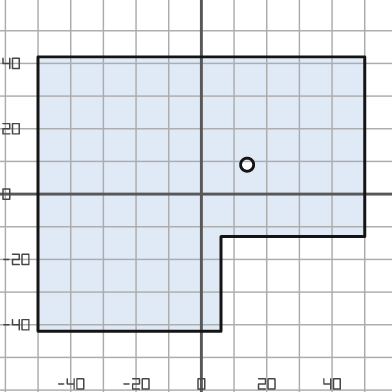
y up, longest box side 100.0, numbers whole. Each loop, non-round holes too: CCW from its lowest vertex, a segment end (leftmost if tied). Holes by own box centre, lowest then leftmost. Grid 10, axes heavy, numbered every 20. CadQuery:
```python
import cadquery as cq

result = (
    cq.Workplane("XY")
    .moveTo(-50.0, -42.0)
    .lineTo(6.0, -42.0)
    .lineTo(6.0, -13.0)
    .lineTo(50.0, -13.0)
    .lineTo(50.0, 42.0)
    .lineTo(-50.0, 42.0)
    .close()
    .moveTo(14.0, 9.0)
    .circle(2.0)
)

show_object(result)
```